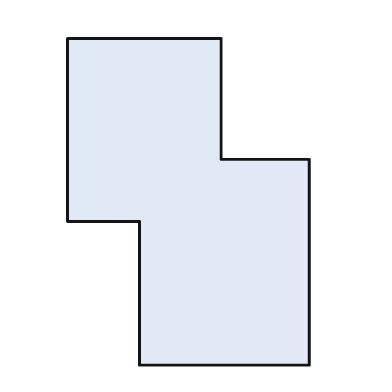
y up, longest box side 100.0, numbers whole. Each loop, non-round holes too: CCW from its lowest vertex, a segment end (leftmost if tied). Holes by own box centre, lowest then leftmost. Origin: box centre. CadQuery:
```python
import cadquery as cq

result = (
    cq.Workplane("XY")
    .moveTo(-15.0, -50.0)
    .lineTo(37.0, -50.0)
    .lineTo(37.0, 13.0)
    .lineTo(10.0, 13.0)
    .lineTo(10.0, 50.0)
    .lineTo(-37.0, 50.0)
    .lineTo(-37.0, -6.0)
    .lineTo(-15.0, -6.0)
    .close()
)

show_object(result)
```